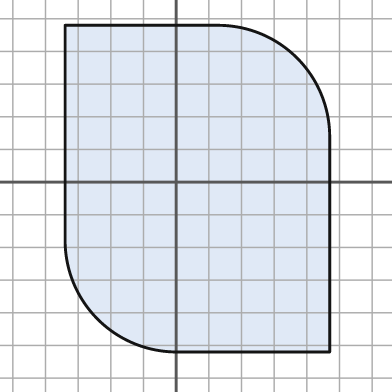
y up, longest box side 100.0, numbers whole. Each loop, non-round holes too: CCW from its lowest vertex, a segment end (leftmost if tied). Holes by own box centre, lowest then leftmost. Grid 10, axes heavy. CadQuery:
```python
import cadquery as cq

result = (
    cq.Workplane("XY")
    .moveTo(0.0, -52.0)
    .lineTo(47.0, -52.0)
    .lineTo(47.0, 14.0)
    .threePointArc((37.0, 38.0), (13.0, 48.0))
    .lineTo(-34.0, 48.0)
    .lineTo(-34.0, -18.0)
    .threePointArc((-24.0, -42.0), (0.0, -52.0))
    .close()
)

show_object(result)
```